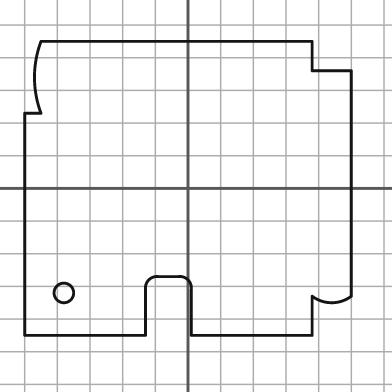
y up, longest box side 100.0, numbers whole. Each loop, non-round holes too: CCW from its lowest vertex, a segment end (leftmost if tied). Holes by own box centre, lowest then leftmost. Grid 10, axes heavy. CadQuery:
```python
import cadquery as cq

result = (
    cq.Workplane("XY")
    .moveTo(-50.0, -45.0)
    .lineTo(-13.0, -45.0)
    .lineTo(-13.0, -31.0)
    .threePointArc((-12.0, -28.0), (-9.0, -27.0))
    .lineTo(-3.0, -27.0)
    .threePointArc((0.0, -28.0), (1.0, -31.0))
    .lineTo(1.0, -45.0)
    .lineTo(38.0, -45.0)
    .lineTo(38.0, -33.0)
    .threePointArc((44.0, -35.0), (50.0, -33.0))
    .lineTo(50.0, 36.0)
    .lineTo(38.0, 36.0)
    .lineTo(38.0, 45.0)
    .lineTo(-45.0, 45.0)
    .threePointArc((-47.0, 34.0), (-45.0, 23.0))
    .lineTo(-50.0, 23.0)
    .close()
    .moveTo(-38.0, -32.0)
    .circle(3.0)
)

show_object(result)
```